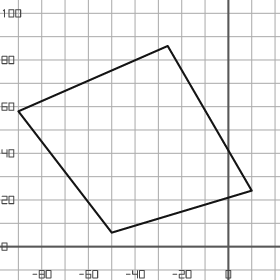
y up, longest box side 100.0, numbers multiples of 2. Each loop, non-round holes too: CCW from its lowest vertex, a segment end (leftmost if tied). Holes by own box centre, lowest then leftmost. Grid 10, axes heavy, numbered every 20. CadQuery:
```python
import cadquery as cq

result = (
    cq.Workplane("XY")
    .moveTo(-50.0, 6.0)
    .lineTo(10.0, 24.0)
    .lineTo(-26.0, 86.0)
    .lineTo(-90.0, 58.0)
    .close()
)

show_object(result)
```